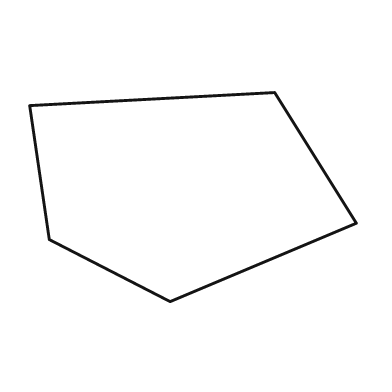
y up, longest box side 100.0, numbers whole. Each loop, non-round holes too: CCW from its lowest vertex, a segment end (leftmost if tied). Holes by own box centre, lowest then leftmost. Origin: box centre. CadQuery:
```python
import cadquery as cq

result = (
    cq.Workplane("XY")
    .moveTo(-7.0, -32.0)
    .lineTo(50.0, -8.0)
    .lineTo(25.0, 32.0)
    .lineTo(-50.0, 28.0)
    .lineTo(-44.0, -13.0)
    .close()
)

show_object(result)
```